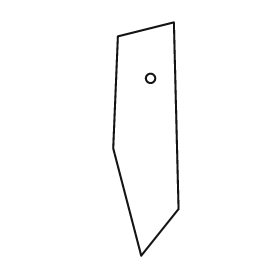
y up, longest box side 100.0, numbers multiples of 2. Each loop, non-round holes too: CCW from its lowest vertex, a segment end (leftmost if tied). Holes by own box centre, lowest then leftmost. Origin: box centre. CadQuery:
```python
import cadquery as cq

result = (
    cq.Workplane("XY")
    .moveTo(-2.0, -50.0)
    .lineTo(14.0, -30.0)
    .lineTo(12.0, 50.0)
    .lineTo(-12.0, 44.0)
    .lineTo(-14.0, -4.0)
    .close()
    .moveTo(2.0, 26.0)
    .circle(2.0)
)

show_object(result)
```